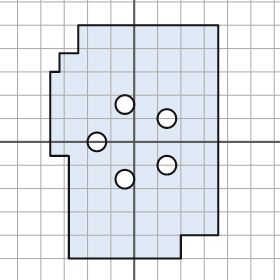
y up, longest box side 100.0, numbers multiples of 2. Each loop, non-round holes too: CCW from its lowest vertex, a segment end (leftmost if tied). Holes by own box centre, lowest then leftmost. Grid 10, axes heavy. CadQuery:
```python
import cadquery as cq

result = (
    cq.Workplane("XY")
    .moveTo(-28.0, -50.0)
    .lineTo(20.0, -50.0)
    .lineTo(20.0, -40.0)
    .lineTo(36.0, -40.0)
    .lineTo(36.0, 50.0)
    .lineTo(-24.0, 50.0)
    .lineTo(-24.0, 38.0)
    .lineTo(-32.0, 38.0)
    .lineTo(-32.0, 30.0)
    .lineTo(-36.0, 30.0)
    .lineTo(-36.0, -6.0)
    .lineTo(-28.0, -6.0)
    .close()
    .moveTo(-4.0, -16.0)
    .circle(4.0)
    .moveTo(14.0, -10.0)
    .circle(4.0)
    .moveTo(-16.0, 0.0)
    .circle(4.0)
    .moveTo(14.0, 10.0)
    .circle(4.0)
    .moveTo(-4.0, 16.0)
    .circle(4.0)
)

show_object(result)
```